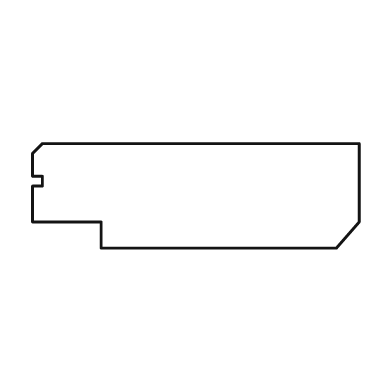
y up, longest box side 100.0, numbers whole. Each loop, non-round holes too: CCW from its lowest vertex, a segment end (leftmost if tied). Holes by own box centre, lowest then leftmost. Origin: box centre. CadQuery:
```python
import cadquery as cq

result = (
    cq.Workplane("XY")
    .moveTo(-29.0, -16.0)
    .lineTo(43.0, -16.0)
    .lineTo(50.0, -8.0)
    .lineTo(50.0, 16.0)
    .lineTo(-47.0, 16.0)
    .lineTo(-50.0, 13.0)
    .lineTo(-50.0, 6.0)
    .lineTo(-47.0, 6.0)
    .lineTo(-47.0, 3.0)
    .lineTo(-50.0, 3.0)
    .lineTo(-50.0, -8.0)
    .lineTo(-29.0, -8.0)
    .close()
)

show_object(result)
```